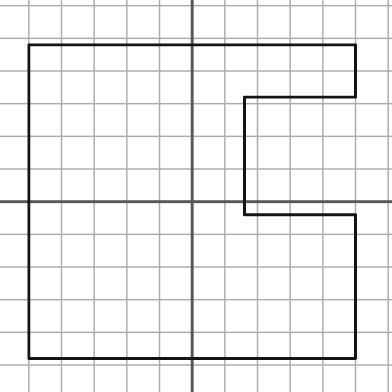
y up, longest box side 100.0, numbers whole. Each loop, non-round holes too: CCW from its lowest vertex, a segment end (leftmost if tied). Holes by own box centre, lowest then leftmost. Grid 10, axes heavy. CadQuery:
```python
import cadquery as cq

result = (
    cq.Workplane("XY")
    .moveTo(-50.0, -48.0)
    .lineTo(50.0, -48.0)
    .lineTo(50.0, -4.0)
    .lineTo(16.0, -4.0)
    .lineTo(16.0, 32.0)
    .lineTo(50.0, 32.0)
    .lineTo(50.0, 48.0)
    .lineTo(-50.0, 48.0)
    .close()
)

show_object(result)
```